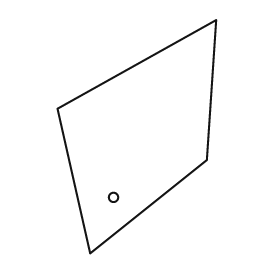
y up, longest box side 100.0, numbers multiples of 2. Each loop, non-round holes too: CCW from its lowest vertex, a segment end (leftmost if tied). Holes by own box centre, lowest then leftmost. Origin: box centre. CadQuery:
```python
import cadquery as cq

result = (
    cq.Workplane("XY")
    .moveTo(-20.0, -50.0)
    .lineTo(30.0, -10.0)
    .lineTo(34.0, 50.0)
    .lineTo(-34.0, 12.0)
    .close()
    .moveTo(-10.0, -26.0)
    .circle(2.0)
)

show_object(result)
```